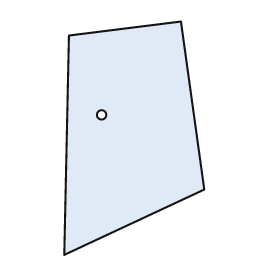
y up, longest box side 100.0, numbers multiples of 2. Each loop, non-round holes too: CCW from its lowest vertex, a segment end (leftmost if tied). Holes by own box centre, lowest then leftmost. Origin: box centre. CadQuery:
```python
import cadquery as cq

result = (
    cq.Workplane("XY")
    .moveTo(-30.0, -50.0)
    .lineTo(30.0, -22.0)
    .lineTo(20.0, 50.0)
    .lineTo(-28.0, 44.0)
    .close()
    .moveTo(-14.0, 10.0)
    .circle(2.0)
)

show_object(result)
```